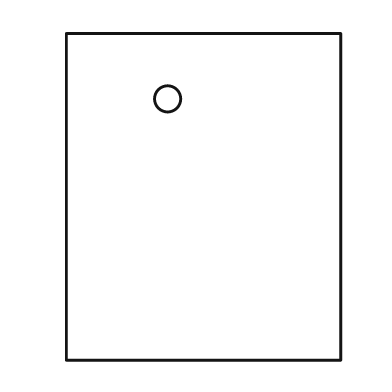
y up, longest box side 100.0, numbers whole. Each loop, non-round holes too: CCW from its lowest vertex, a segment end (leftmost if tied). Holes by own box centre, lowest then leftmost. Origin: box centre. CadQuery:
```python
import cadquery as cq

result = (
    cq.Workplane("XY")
    .moveTo(-42.0, -50.0)
    .lineTo(42.0, -50.0)
    .lineTo(42.0, 50.0)
    .lineTo(-42.0, 50.0)
    .close()
    .moveTo(-11.0, 30.0)
    .circle(4.0)
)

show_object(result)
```